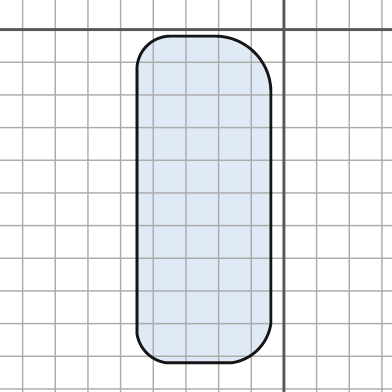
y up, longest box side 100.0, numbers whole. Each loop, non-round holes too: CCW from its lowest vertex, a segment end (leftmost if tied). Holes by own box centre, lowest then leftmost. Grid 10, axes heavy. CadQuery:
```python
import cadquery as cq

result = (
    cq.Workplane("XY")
    .moveTo(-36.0, -102.0)
    .lineTo(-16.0, -102.0)
    .threePointArc((-8.0, -98.0), (-4.0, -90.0))
    .lineTo(-4.0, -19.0)
    .threePointArc((-9.0, -7.0), (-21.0, -2.0))
    .lineTo(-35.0, -2.0)
    .threePointArc((-42.0, -5.0), (-45.0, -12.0))
    .lineTo(-45.0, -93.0)
    .threePointArc((-42.0, -99.0), (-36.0, -102.0))
    .close()
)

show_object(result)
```